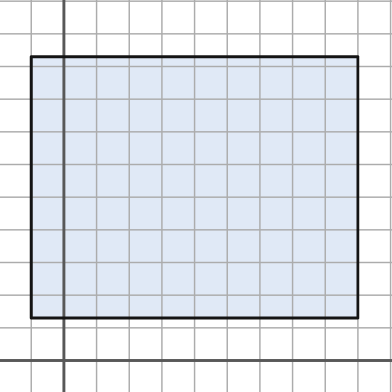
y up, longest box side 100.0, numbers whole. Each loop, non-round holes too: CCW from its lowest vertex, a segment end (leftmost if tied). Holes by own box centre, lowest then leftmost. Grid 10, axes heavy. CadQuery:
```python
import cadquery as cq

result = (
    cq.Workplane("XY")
    .moveTo(-10.0, 13.0)
    .lineTo(90.0, 13.0)
    .lineTo(90.0, 93.0)
    .lineTo(-10.0, 93.0)
    .close()
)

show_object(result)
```